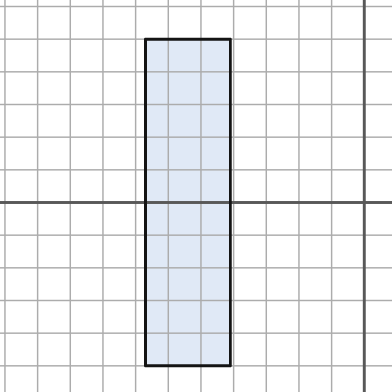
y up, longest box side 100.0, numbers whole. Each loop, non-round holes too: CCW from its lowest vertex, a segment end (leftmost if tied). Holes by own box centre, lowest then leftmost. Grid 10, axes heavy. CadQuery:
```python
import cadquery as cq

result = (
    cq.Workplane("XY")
    .moveTo(-67.0, -50.0)
    .lineTo(-41.0, -50.0)
    .lineTo(-41.0, 50.0)
    .lineTo(-67.0, 50.0)
    .close()
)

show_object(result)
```